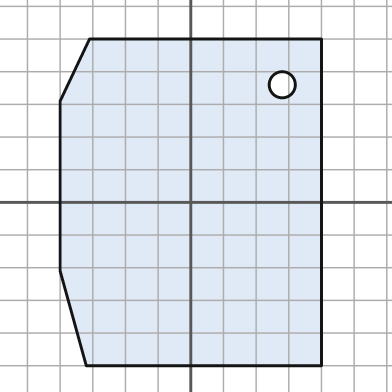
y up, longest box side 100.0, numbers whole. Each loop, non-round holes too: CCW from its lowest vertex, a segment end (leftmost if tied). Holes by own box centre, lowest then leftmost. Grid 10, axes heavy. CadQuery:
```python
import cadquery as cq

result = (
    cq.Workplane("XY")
    .moveTo(-32.0, -50.0)
    .lineTo(40.0, -50.0)
    .lineTo(40.0, 50.0)
    .lineTo(-31.0, 50.0)
    .lineTo(-40.0, 31.0)
    .lineTo(-40.0, -21.0)
    .close()
    .moveTo(28.0, 36.0)
    .circle(4.0)
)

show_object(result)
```